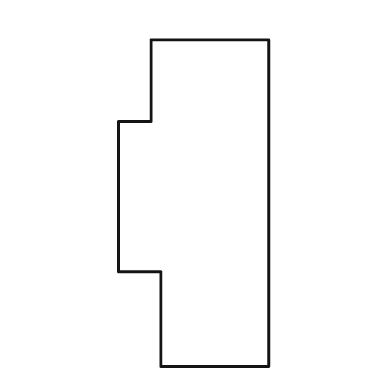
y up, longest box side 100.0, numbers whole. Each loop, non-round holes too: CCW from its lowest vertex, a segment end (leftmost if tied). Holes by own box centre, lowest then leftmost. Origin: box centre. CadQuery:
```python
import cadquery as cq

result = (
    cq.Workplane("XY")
    .moveTo(-10.0, -50.0)
    .lineTo(23.0, -50.0)
    .lineTo(23.0, 50.0)
    .lineTo(-13.0, 50.0)
    .lineTo(-13.0, 25.0)
    .lineTo(-23.0, 25.0)
    .lineTo(-23.0, -21.0)
    .lineTo(-10.0, -21.0)
    .close()
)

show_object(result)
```